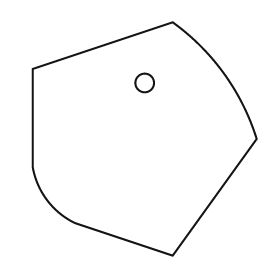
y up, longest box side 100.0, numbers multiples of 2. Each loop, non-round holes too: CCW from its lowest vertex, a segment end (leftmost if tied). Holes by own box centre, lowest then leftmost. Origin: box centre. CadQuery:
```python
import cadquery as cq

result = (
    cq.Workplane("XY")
    .moveTo(12.0, -50.0)
    .lineTo(48.0, 0.0)
    .threePointArc((34.0, 28.0), (12.0, 50.0))
    .lineTo(-48.0, 30.0)
    .lineTo(-48.0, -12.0)
    .threePointArc((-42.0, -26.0), (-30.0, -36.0))
    .close()
    .moveTo(0.0, 24.0)
    .circle(4.0)
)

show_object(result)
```